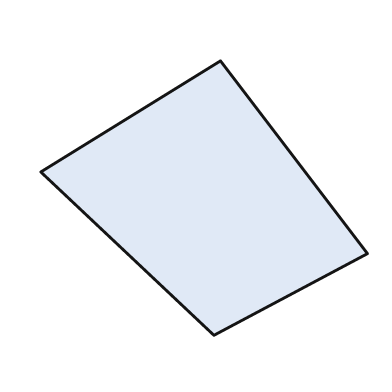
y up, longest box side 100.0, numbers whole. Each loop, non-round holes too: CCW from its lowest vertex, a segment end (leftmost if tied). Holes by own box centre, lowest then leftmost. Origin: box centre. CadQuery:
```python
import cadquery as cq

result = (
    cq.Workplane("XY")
    .moveTo(3.0, -42.0)
    .lineTo(50.0, -17.0)
    .lineTo(5.0, 42.0)
    .lineTo(-50.0, 8.0)
    .close()
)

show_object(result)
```